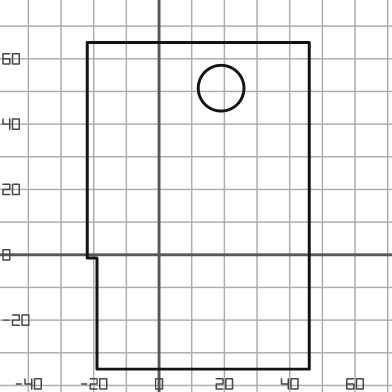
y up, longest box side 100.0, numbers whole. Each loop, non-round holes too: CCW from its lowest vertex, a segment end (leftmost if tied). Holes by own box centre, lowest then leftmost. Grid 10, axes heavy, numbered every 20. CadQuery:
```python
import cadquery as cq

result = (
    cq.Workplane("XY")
    .moveTo(-19.0, -35.0)
    .lineTo(46.0, -35.0)
    .lineTo(46.0, 65.0)
    .lineTo(-22.0, 65.0)
    .lineTo(-22.0, -1.0)
    .lineTo(-19.0, -1.0)
    .close()
    .moveTo(19.0, 51.0)
    .circle(7.0)
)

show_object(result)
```